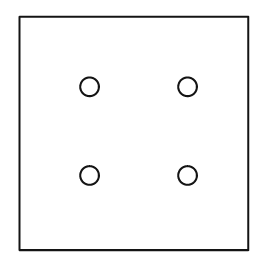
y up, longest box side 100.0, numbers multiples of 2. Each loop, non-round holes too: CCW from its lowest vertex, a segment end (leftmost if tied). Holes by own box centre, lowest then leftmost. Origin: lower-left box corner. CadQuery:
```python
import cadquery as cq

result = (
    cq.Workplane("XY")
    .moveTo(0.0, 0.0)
    .lineTo(98.0, 0.0)
    .lineTo(98.0, 100.0)
    .lineTo(0.0, 100.0)
    .close()
    .moveTo(30.0, 32.0)
    .circle(4.0)
    .moveTo(72.0, 32.0)
    .circle(4.0)
    .moveTo(30.0, 70.0)
    .circle(4.0)
    .moveTo(72.0, 70.0)
    .circle(4.0)
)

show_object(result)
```